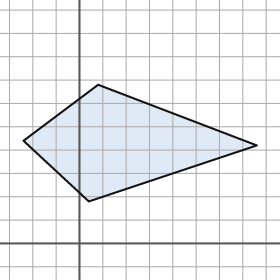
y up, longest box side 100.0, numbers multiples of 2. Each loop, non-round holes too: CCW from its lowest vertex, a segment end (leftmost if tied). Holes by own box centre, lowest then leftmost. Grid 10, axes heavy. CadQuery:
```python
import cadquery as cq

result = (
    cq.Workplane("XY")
    .moveTo(4.0, 18.0)
    .lineTo(76.0, 42.0)
    .lineTo(8.0, 68.0)
    .lineTo(-24.0, 44.0)
    .close()
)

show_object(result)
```